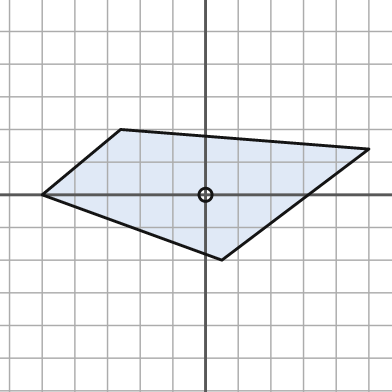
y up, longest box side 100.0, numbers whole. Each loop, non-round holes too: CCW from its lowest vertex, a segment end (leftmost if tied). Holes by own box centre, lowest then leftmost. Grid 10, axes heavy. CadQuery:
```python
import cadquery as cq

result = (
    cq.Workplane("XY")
    .moveTo(5.0, -20.0)
    .lineTo(50.0, 14.0)
    .lineTo(-26.0, 20.0)
    .lineTo(-50.0, 0.0)
    .close()
    .moveTo(0.0, 0.0)
    .circle(2.0)
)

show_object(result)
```